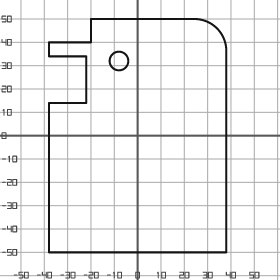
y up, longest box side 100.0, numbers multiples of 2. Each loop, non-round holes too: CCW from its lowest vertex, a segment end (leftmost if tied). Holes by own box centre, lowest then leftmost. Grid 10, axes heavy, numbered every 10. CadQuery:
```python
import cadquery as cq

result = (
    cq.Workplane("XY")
    .moveTo(-38.0, -50.0)
    .lineTo(38.0, -50.0)
    .lineTo(38.0, 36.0)
    .threePointArc((34.0, 46.0), (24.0, 50.0))
    .lineTo(-20.0, 50.0)
    .lineTo(-20.0, 40.0)
    .lineTo(-38.0, 40.0)
    .lineTo(-38.0, 34.0)
    .lineTo(-22.0, 34.0)
    .lineTo(-22.0, 14.0)
    .lineTo(-38.0, 14.0)
    .close()
    .moveTo(-8.0, 32.0)
    .circle(4.0)
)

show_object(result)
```